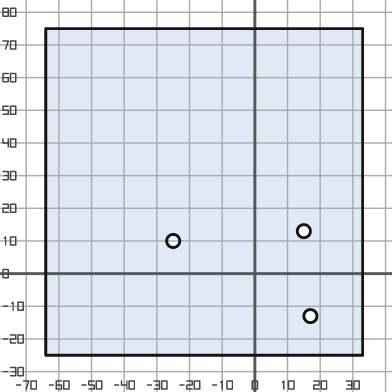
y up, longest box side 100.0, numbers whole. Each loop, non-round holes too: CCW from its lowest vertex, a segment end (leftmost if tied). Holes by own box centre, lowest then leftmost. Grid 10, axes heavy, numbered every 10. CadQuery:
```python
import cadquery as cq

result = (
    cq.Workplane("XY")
    .moveTo(-64.0, -25.0)
    .lineTo(33.0, -25.0)
    .lineTo(33.0, 75.0)
    .lineTo(-64.0, 75.0)
    .close()
    .moveTo(17.0, -13.0)
    .circle(2.0)
    .moveTo(-25.0, 10.0)
    .circle(2.0)
    .moveTo(15.0, 13.0)
    .circle(2.0)
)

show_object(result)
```